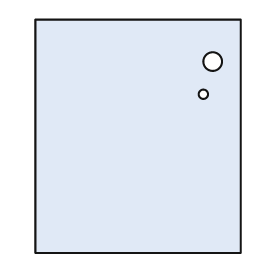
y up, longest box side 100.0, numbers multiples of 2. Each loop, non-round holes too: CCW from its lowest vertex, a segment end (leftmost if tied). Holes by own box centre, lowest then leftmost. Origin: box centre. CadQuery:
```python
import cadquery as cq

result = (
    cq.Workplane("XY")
    .moveTo(-44.0, -50.0)
    .lineTo(44.0, -50.0)
    .lineTo(44.0, 50.0)
    .lineTo(-44.0, 50.0)
    .close()
    .moveTo(28.0, 18.0)
    .circle(2.0)
    .moveTo(32.0, 32.0)
    .circle(4.0)
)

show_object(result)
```